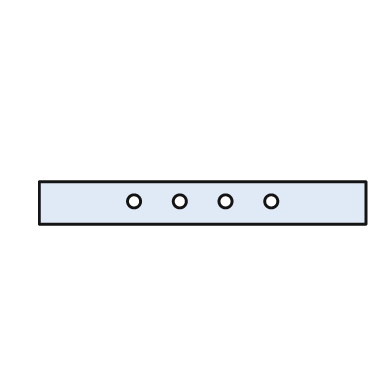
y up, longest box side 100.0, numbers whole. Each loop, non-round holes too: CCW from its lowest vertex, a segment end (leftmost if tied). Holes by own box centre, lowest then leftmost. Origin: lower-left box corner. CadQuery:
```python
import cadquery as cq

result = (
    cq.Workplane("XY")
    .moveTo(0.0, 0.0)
    .lineTo(100.0, 0.0)
    .lineTo(100.0, 13.0)
    .lineTo(0.0, 13.0)
    .close()
    .moveTo(29.0, 7.0)
    .circle(2.0)
    .moveTo(43.0, 7.0)
    .circle(2.0)
    .moveTo(57.0, 7.0)
    .circle(2.0)
    .moveTo(71.0, 7.0)
    .circle(2.0)
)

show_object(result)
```